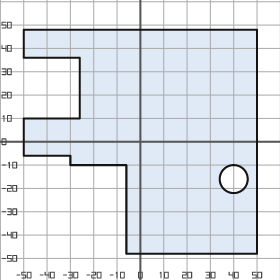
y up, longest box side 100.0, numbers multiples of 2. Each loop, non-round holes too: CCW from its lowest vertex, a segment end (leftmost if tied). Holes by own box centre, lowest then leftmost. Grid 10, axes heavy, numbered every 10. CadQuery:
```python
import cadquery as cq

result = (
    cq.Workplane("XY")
    .moveTo(-6.0, -48.0)
    .lineTo(50.0, -48.0)
    .lineTo(50.0, 48.0)
    .lineTo(-50.0, 48.0)
    .lineTo(-50.0, 36.0)
    .lineTo(-26.0, 36.0)
    .lineTo(-26.0, 10.0)
    .lineTo(-50.0, 10.0)
    .lineTo(-50.0, -6.0)
    .lineTo(-30.0, -6.0)
    .lineTo(-30.0, -10.0)
    .lineTo(-6.0, -10.0)
    .close()
    .moveTo(40.0, -16.0)
    .circle(6.0)
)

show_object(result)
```